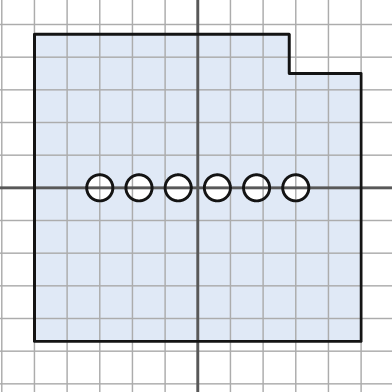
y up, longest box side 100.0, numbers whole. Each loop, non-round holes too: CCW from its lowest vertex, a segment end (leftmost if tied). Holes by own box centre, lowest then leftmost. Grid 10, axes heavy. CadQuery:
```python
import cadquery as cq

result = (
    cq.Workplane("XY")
    .moveTo(-50.0, -47.0)
    .lineTo(50.0, -47.0)
    .lineTo(50.0, 35.0)
    .lineTo(28.0, 35.0)
    .lineTo(28.0, 47.0)
    .lineTo(-50.0, 47.0)
    .close()
    .moveTo(-30.0, 0.0)
    .circle(4.0)
    .moveTo(-18.0, 0.0)
    .circle(4.0)
    .moveTo(-6.0, 0.0)
    .circle(4.0)
    .moveTo(6.0, 0.0)
    .circle(4.0)
    .moveTo(18.0, 0.0)
    .circle(4.0)
    .moveTo(30.0, 0.0)
    .circle(4.0)
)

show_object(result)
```